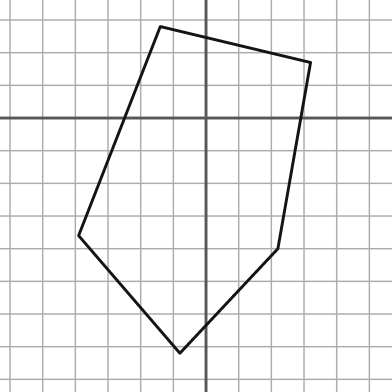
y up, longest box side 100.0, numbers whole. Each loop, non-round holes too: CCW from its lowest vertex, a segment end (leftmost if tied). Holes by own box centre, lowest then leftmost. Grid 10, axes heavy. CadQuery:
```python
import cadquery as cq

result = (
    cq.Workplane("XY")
    .moveTo(-8.0, -72.0)
    .lineTo(22.0, -40.0)
    .lineTo(32.0, 17.0)
    .lineTo(-14.0, 28.0)
    .lineTo(-39.0, -36.0)
    .close()
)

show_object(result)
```